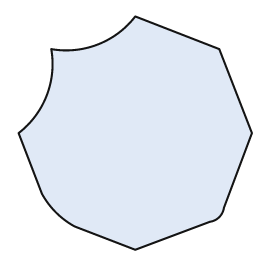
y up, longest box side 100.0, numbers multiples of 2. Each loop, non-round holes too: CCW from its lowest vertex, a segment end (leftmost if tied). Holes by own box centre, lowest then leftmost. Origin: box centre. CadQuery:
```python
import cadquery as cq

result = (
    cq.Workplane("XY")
    .moveTo(0.0, -50.0)
    .lineTo(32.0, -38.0)
    .threePointArc((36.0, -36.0), (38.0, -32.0))
    .lineTo(50.0, 0.0)
    .lineTo(36.0, 36.0)
    .lineTo(0.0, 50.0)
    .threePointArc((-16.0, 38.0), (-36.0, 36.0))
    .threePointArc((-38.0, 16.0), (-50.0, 0.0))
    .lineTo(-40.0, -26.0)
    .threePointArc((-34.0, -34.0), (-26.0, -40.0))
    .close()
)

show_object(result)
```